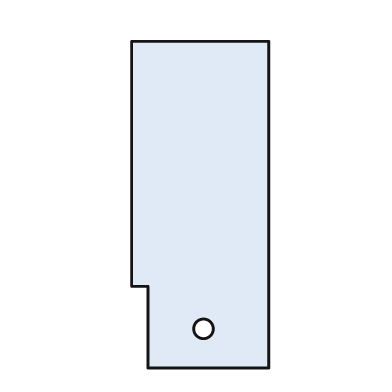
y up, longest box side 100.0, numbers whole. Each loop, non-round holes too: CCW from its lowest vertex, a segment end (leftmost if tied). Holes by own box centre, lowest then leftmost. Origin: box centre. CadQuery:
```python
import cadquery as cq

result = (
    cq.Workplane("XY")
    .moveTo(-16.0, -50.0)
    .lineTo(21.0, -50.0)
    .lineTo(21.0, 50.0)
    .lineTo(-21.0, 50.0)
    .lineTo(-21.0, -25.0)
    .lineTo(-16.0, -25.0)
    .close()
    .moveTo(1.0, -38.0)
    .circle(3.0)
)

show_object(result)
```